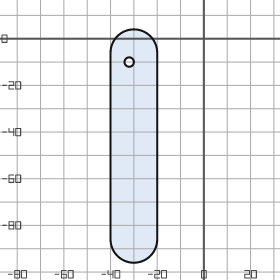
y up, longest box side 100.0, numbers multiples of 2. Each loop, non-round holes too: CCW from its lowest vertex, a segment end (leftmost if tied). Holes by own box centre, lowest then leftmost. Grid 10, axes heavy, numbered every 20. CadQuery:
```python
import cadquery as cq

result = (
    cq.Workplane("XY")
    .moveTo(-40.0, -86.0)
    .threePointArc((-30.0, -96.0), (-20.0, -86.0))
    .lineTo(-20.0, -6.0)
    .threePointArc((-30.0, 4.0), (-40.0, -6.0))
    .close()
    .moveTo(-32.0, -10.0)
    .circle(2.0)
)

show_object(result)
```